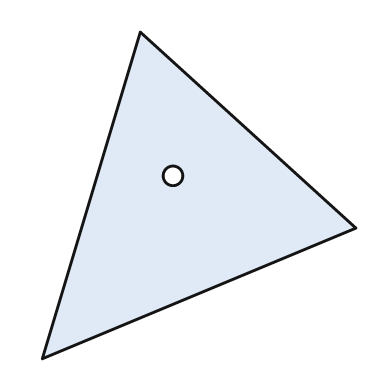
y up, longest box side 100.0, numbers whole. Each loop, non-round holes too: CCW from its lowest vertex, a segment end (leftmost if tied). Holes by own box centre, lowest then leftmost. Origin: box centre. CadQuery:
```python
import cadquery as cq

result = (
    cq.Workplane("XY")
    .moveTo(-48.0, -50.0)
    .lineTo(48.0, -10.0)
    .lineTo(-18.0, 50.0)
    .close()
    .moveTo(-8.0, 6.0)
    .circle(3.0)
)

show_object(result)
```